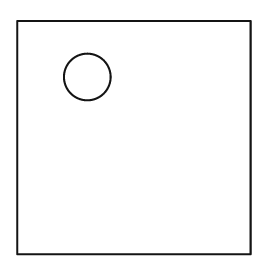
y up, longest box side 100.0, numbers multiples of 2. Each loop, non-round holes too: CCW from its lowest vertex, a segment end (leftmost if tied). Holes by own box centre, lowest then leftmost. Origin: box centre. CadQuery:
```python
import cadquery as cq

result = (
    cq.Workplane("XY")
    .moveTo(-50.0, -50.0)
    .lineTo(50.0, -50.0)
    .lineTo(50.0, 50.0)
    .lineTo(-50.0, 50.0)
    .close()
    .moveTo(-20.0, 26.0)
    .circle(10.0)
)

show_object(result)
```